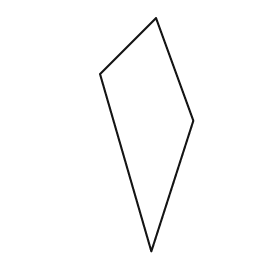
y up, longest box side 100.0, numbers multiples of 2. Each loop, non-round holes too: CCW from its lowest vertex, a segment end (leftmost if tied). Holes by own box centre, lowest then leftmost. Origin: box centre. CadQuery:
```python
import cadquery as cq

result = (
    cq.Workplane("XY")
    .moveTo(2.0, -50.0)
    .lineTo(20.0, 6.0)
    .lineTo(4.0, 50.0)
    .lineTo(-20.0, 26.0)
    .close()
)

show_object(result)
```